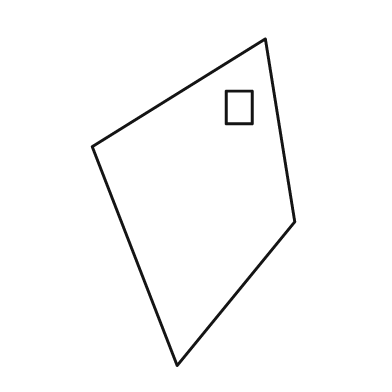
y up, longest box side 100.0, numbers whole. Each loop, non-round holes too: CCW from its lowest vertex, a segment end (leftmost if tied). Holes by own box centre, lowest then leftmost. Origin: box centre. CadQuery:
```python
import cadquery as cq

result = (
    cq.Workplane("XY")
    .moveTo(-5.0, -50.0)
    .lineTo(31.0, -6.0)
    .lineTo(22.0, 50.0)
    .lineTo(-31.0, 17.0)
    .close()
    .moveTo(10.0, 24.0)
    .lineTo(18.0, 24.0)
    .lineTo(18.0, 34.0)
    .lineTo(10.0, 34.0)
    .close()
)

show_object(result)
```